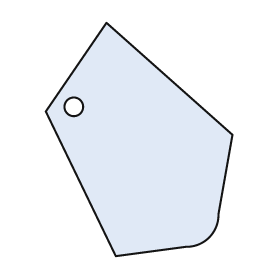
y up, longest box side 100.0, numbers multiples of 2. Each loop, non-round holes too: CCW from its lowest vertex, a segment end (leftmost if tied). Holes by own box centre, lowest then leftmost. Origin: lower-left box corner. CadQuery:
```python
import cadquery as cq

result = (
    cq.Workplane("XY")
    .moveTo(30.0, 0.0)
    .lineTo(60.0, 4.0)
    .threePointArc((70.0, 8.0), (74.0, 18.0))
    .lineTo(80.0, 52.0)
    .lineTo(26.0, 100.0)
    .lineTo(0.0, 62.0)
    .close()
    .moveTo(12.0, 64.0)
    .circle(4.0)
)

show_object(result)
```